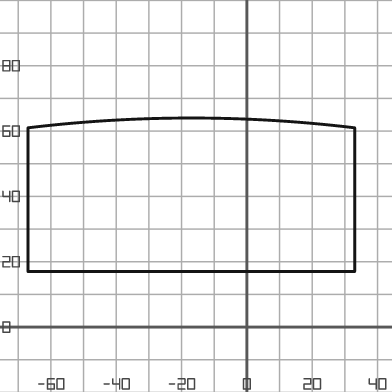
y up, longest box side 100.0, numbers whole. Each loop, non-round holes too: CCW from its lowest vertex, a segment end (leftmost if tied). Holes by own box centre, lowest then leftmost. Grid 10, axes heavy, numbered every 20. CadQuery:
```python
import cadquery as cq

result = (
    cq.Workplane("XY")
    .moveTo(-67.0, 17.0)
    .lineTo(33.0, 17.0)
    .lineTo(33.0, 61.0)
    .threePointArc((-17.0, 64.0), (-67.0, 61.0))
    .close()
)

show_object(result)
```